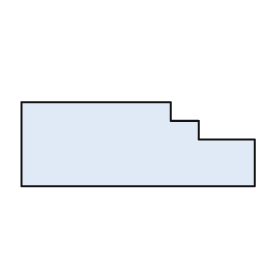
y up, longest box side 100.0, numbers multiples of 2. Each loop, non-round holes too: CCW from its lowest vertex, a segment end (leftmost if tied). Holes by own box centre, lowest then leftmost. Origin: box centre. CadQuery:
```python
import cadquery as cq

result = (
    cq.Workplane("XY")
    .moveTo(-50.0, -18.0)
    .lineTo(50.0, -18.0)
    .lineTo(50.0, 2.0)
    .lineTo(26.0, 2.0)
    .lineTo(26.0, 10.0)
    .lineTo(14.0, 10.0)
    .lineTo(14.0, 18.0)
    .lineTo(-50.0, 18.0)
    .close()
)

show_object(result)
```